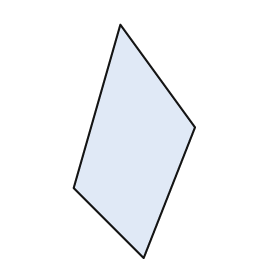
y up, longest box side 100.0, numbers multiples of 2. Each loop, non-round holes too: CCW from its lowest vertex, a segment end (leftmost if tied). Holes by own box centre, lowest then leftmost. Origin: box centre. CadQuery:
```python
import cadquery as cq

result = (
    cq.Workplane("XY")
    .moveTo(4.0, -50.0)
    .lineTo(26.0, 6.0)
    .lineTo(-6.0, 50.0)
    .lineTo(-26.0, -20.0)
    .close()
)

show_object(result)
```